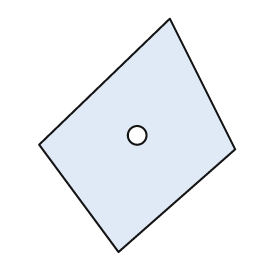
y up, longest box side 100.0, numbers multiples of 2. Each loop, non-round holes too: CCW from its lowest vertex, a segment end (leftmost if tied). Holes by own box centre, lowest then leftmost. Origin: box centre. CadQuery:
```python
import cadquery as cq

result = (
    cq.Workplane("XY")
    .moveTo(-8.0, -50.0)
    .lineTo(42.0, -6.0)
    .lineTo(14.0, 50.0)
    .lineTo(-42.0, -4.0)
    .close()
    .moveTo(0.0, 0.0)
    .circle(4.0)
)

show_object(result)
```